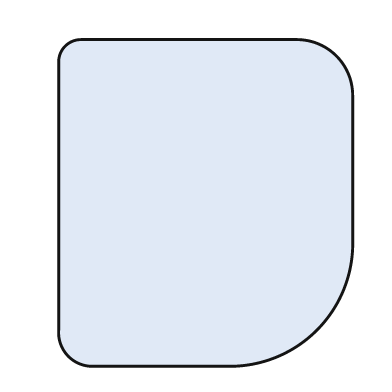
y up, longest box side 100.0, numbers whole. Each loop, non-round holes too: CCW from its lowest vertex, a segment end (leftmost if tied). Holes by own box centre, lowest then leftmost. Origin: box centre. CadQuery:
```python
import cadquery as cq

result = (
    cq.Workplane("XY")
    .moveTo(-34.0, -50.0)
    .lineTo(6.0, -50.0)
    .threePointArc((34.0, -39.0), (45.0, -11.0))
    .lineTo(45.0, 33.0)
    .threePointArc((40.0, 45.0), (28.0, 50.0))
    .lineTo(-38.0, 50.0)
    .threePointArc((-43.0, 48.0), (-45.0, 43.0))
    .lineTo(-45.0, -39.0)
    .threePointArc((-42.0, -47.0), (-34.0, -50.0))
    .close()
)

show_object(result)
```